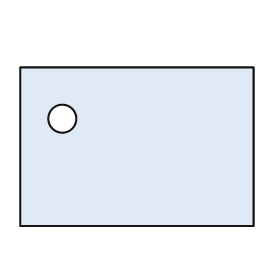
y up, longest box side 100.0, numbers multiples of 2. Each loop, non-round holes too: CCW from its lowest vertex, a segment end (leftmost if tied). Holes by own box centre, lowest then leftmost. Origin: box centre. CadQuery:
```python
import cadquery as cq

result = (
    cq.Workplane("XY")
    .moveTo(-50.0, -34.0)
    .lineTo(50.0, -34.0)
    .lineTo(50.0, 34.0)
    .lineTo(-50.0, 34.0)
    .close()
    .moveTo(-32.0, 12.0)
    .circle(6.0)
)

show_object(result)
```